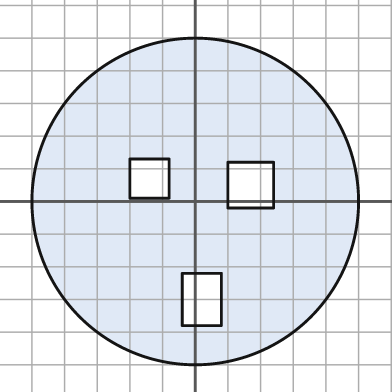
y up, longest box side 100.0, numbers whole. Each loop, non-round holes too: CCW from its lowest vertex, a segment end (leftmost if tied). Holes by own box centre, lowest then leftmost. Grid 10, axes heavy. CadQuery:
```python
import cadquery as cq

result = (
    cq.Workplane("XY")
    .moveTo(0.0, 0.0)
    .circle(50.0)
    .moveTo(-4.0, -38.0)
    .lineTo(8.0, -38.0)
    .lineTo(8.0, -22.0)
    .lineTo(-4.0, -22.0)
    .close()
    .moveTo(10.0, -2.0)
    .lineTo(24.0, -2.0)
    .lineTo(24.0, 12.0)
    .lineTo(10.0, 12.0)
    .close()
    .moveTo(-20.0, 1.0)
    .lineTo(-8.0, 1.0)
    .lineTo(-8.0, 13.0)
    .lineTo(-20.0, 13.0)
    .close()
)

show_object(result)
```